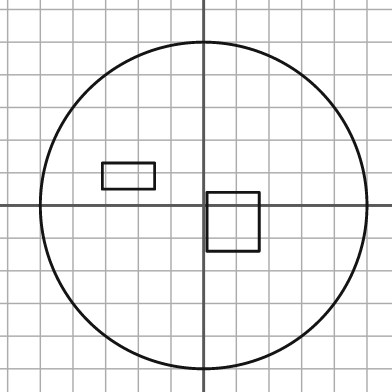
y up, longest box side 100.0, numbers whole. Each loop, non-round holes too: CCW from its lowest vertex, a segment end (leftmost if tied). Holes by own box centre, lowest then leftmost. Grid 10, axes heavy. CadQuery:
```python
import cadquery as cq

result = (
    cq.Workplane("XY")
    .moveTo(0.0, 0.0)
    .circle(50.0)
    .moveTo(1.0, -14.0)
    .lineTo(17.0, -14.0)
    .lineTo(17.0, 4.0)
    .lineTo(1.0, 4.0)
    .close()
    .moveTo(-31.0, 5.0)
    .lineTo(-15.0, 5.0)
    .lineTo(-15.0, 13.0)
    .lineTo(-31.0, 13.0)
    .close()
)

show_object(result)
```